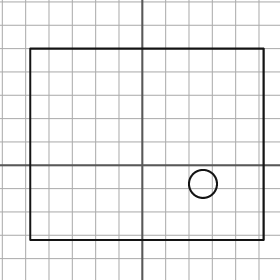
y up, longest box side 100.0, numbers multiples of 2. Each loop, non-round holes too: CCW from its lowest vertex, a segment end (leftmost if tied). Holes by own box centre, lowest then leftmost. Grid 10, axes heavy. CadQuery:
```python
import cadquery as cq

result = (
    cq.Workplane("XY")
    .moveTo(-48.0, -32.0)
    .lineTo(52.0, -32.0)
    .lineTo(52.0, 50.0)
    .lineTo(-48.0, 50.0)
    .close()
    .moveTo(26.0, -8.0)
    .circle(6.0)
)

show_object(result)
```